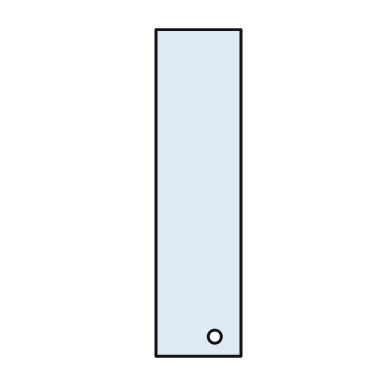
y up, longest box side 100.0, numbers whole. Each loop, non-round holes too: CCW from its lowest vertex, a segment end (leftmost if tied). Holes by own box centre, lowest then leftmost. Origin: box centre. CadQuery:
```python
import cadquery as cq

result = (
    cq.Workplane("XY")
    .moveTo(-13.0, -50.0)
    .lineTo(13.0, -50.0)
    .lineTo(13.0, 50.0)
    .lineTo(-13.0, 50.0)
    .close()
    .moveTo(5.0, -44.0)
    .circle(2.0)
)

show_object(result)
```